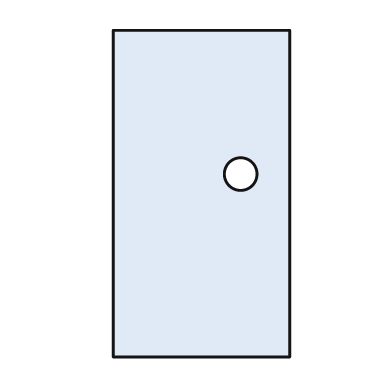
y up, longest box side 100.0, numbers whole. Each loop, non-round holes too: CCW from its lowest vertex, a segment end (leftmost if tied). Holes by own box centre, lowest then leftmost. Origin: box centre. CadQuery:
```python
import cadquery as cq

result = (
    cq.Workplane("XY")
    .moveTo(-27.0, -50.0)
    .lineTo(27.0, -50.0)
    .lineTo(27.0, 50.0)
    .lineTo(-27.0, 50.0)
    .close()
    .moveTo(12.0, 6.0)
    .circle(5.0)
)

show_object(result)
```